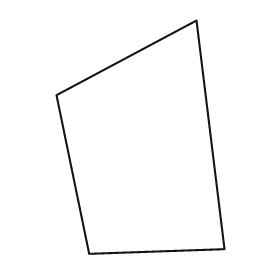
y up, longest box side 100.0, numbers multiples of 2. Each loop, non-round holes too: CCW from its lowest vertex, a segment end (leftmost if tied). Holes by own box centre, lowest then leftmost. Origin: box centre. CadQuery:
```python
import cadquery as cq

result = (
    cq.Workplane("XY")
    .moveTo(-22.0, -50.0)
    .lineTo(36.0, -48.0)
    .lineTo(24.0, 50.0)
    .lineTo(-36.0, 18.0)
    .close()
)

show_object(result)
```